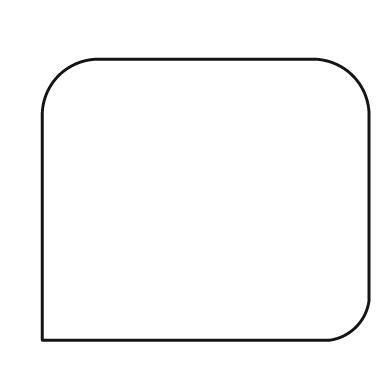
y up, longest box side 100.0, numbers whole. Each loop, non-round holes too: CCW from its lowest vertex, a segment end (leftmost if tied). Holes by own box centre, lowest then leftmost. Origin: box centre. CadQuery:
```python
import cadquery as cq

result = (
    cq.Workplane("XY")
    .moveTo(-50.0, -43.0)
    .lineTo(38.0, -43.0)
    .threePointArc((46.0, -39.0), (50.0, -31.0))
    .lineTo(50.0, 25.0)
    .threePointArc((45.0, 38.0), (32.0, 43.0))
    .lineTo(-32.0, 43.0)
    .threePointArc((-45.0, 38.0), (-50.0, 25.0))
    .close()
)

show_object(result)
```